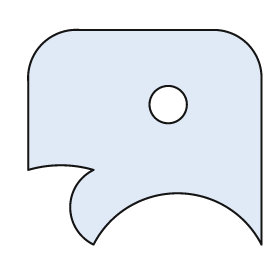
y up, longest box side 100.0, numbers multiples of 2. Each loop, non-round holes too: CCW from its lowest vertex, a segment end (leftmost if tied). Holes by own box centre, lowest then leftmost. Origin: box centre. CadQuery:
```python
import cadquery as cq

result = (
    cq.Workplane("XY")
    .moveTo(-22.0, -46.0)
    .threePointArc((14.0, -24.0), (50.0, -46.0))
    .lineTo(50.0, 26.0)
    .threePointArc((44.0, 40.0), (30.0, 46.0))
    .lineTo(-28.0, 46.0)
    .threePointArc((-44.0, 40.0), (-50.0, 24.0))
    .lineTo(-50.0, -14.0)
    .threePointArc((-36.0, -12.0), (-22.0, -14.0))
    .threePointArc((-32.0, -30.0), (-22.0, -46.0))
    .close()
    .moveTo(10.0, 14.0)
    .circle(8.0)
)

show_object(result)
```